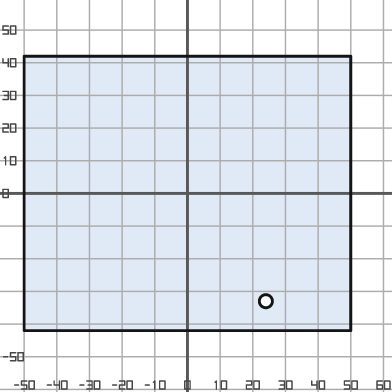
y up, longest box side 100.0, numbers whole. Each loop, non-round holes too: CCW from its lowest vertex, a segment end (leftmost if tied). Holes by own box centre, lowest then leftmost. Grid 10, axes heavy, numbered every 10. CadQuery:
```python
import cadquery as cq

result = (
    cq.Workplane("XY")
    .moveTo(-50.0, -42.0)
    .lineTo(50.0, -42.0)
    .lineTo(50.0, 42.0)
    .lineTo(-50.0, 42.0)
    .close()
    .moveTo(24.0, -33.0)
    .circle(2.0)
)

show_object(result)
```